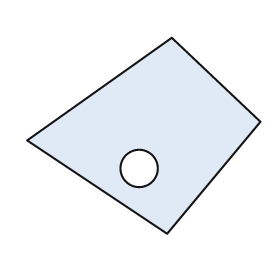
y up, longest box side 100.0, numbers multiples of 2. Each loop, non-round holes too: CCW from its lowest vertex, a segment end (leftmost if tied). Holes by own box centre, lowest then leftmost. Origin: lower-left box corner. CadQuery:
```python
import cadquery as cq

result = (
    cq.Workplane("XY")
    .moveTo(60.0, 0.0)
    .lineTo(100.0, 48.0)
    .lineTo(62.0, 84.0)
    .lineTo(0.0, 40.0)
    .close()
    .moveTo(48.0, 28.0)
    .circle(8.0)
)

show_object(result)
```